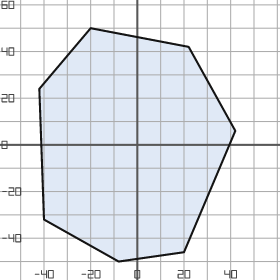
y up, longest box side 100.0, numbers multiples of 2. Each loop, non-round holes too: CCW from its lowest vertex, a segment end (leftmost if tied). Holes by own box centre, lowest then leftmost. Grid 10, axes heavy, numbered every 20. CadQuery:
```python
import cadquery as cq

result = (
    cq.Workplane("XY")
    .moveTo(-8.0, -50.0)
    .lineTo(20.0, -46.0)
    .lineTo(42.0, 6.0)
    .lineTo(22.0, 42.0)
    .lineTo(-20.0, 50.0)
    .lineTo(-42.0, 24.0)
    .lineTo(-40.0, -32.0)
    .close()
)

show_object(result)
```